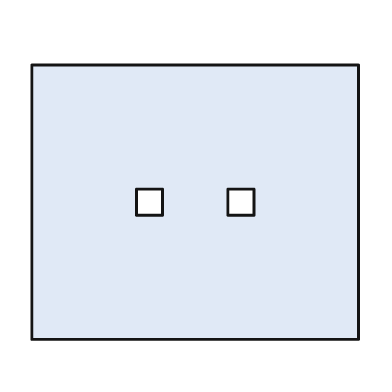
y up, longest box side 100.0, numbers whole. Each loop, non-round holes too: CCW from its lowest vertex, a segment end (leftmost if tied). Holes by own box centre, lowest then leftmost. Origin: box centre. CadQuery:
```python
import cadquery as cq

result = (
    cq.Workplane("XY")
    .moveTo(-50.0, -42.0)
    .lineTo(50.0, -42.0)
    .lineTo(50.0, 42.0)
    .lineTo(-50.0, 42.0)
    .close()
    .moveTo(-18.0, -4.0)
    .lineTo(-10.0, -4.0)
    .lineTo(-10.0, 4.0)
    .lineTo(-18.0, 4.0)
    .close()
    .moveTo(10.0, -4.0)
    .lineTo(18.0, -4.0)
    .lineTo(18.0, 4.0)
    .lineTo(10.0, 4.0)
    .close()
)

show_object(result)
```